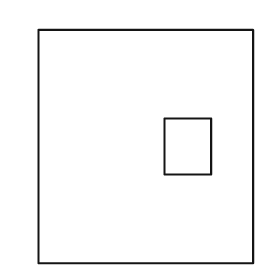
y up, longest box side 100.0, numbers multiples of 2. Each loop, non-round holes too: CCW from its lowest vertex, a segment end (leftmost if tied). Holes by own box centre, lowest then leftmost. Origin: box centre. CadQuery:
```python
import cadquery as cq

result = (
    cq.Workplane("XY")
    .moveTo(-46.0, -50.0)
    .lineTo(46.0, -50.0)
    .lineTo(46.0, 50.0)
    .lineTo(-46.0, 50.0)
    .close()
    .moveTo(8.0, -12.0)
    .lineTo(28.0, -12.0)
    .lineTo(28.0, 12.0)
    .lineTo(8.0, 12.0)
    .close()
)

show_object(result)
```